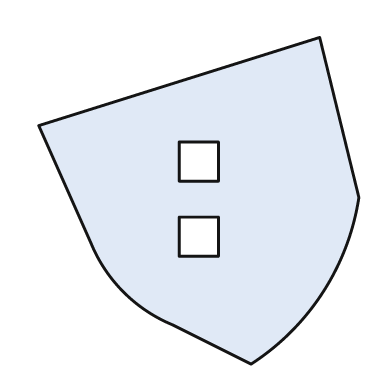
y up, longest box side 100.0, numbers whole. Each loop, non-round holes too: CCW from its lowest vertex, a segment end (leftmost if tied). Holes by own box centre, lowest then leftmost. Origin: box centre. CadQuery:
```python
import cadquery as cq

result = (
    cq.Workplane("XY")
    .moveTo(16.0, -50.0)
    .threePointArc((38.0, -28.0), (49.0, 1.0))
    .lineTo(37.0, 50.0)
    .lineTo(-49.0, 23.0)
    .lineTo(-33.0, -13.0)
    .threePointArc((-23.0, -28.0), (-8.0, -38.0))
    .close()
    .moveTo(-6.0, -17.0)
    .lineTo(6.0, -17.0)
    .lineTo(6.0, -5.0)
    .lineTo(-6.0, -5.0)
    .close()
    .moveTo(-6.0, 6.0)
    .lineTo(6.0, 6.0)
    .lineTo(6.0, 18.0)
    .lineTo(-6.0, 18.0)
    .close()
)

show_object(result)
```